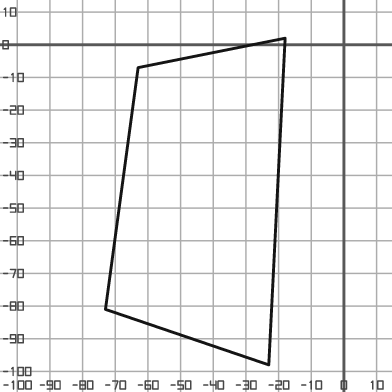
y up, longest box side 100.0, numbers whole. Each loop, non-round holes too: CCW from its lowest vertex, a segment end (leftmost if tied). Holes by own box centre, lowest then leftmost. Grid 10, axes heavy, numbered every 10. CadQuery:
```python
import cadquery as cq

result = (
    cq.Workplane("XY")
    .moveTo(-23.0, -98.0)
    .lineTo(-18.0, 2.0)
    .lineTo(-63.0, -7.0)
    .lineTo(-73.0, -81.0)
    .close()
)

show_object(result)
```